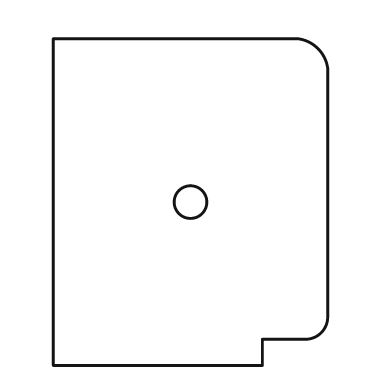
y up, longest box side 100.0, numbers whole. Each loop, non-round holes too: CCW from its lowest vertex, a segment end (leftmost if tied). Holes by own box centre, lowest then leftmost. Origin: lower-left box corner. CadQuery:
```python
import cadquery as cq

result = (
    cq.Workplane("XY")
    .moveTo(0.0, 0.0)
    .lineTo(64.0, 0.0)
    .lineTo(64.0, 8.0)
    .lineTo(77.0, 8.0)
    .threePointArc((82.0, 10.0), (84.0, 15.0))
    .lineTo(84.0, 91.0)
    .threePointArc((81.0, 97.0), (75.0, 100.0))
    .lineTo(0.0, 100.0)
    .close()
    .moveTo(42.0, 50.0)
    .circle(5.0)
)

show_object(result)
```